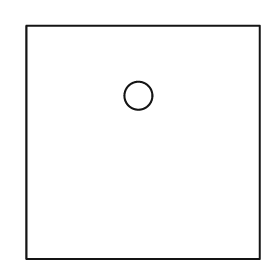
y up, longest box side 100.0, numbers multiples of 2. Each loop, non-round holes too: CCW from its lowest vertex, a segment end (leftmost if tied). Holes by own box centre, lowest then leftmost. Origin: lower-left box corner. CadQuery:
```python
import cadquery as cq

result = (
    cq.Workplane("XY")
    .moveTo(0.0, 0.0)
    .lineTo(100.0, 0.0)
    .lineTo(100.0, 100.0)
    .lineTo(0.0, 100.0)
    .close()
    .moveTo(48.0, 70.0)
    .circle(6.0)
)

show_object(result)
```